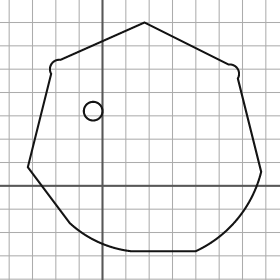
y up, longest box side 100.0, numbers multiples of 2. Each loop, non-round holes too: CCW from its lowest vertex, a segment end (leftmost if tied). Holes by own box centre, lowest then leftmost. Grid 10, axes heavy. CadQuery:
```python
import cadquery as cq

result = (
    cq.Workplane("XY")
    .moveTo(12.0, -28.0)
    .lineTo(40.0, -28.0)
    .threePointArc((58.0, -14.0), (68.0, 6.0))
    .lineTo(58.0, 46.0)
    .threePointArc((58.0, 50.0), (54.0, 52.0))
    .lineTo(18.0, 70.0)
    .lineTo(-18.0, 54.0)
    .threePointArc((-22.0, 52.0), (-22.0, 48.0))
    .lineTo(-32.0, 8.0)
    .lineTo(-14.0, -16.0)
    .threePointArc((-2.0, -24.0), (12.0, -28.0))
    .close()
    .moveTo(-4.0, 32.0)
    .circle(4.0)
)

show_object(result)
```